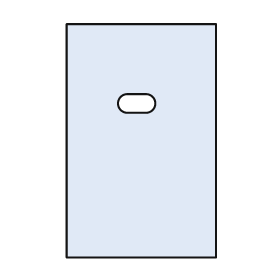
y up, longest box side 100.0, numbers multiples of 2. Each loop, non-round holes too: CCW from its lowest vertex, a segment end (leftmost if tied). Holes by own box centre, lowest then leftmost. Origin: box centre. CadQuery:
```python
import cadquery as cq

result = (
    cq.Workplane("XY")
    .moveTo(-32.0, -50.0)
    .lineTo(32.0, -50.0)
    .lineTo(32.0, 50.0)
    .lineTo(-32.0, 50.0)
    .close()
    .moveTo(-6.0, 12.0)
    .lineTo(2.0, 12.0)
    .threePointArc((6.0, 16.0), (2.0, 20.0))
    .lineTo(-6.0, 20.0)
    .threePointArc((-10.0, 16.0), (-6.0, 12.0))
    .close()
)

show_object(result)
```